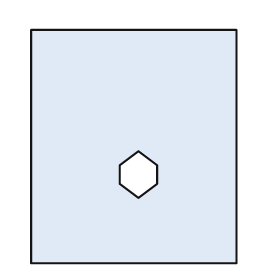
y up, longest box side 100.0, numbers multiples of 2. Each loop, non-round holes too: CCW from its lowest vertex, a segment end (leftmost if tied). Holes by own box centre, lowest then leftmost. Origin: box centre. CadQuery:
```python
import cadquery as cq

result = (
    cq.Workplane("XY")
    .moveTo(-44.0, -50.0)
    .lineTo(44.0, -50.0)
    .lineTo(44.0, 50.0)
    .lineTo(-44.0, 50.0)
    .close()
    .moveTo(2.0, -22.0)
    .lineTo(10.0, -16.0)
    .lineTo(10.0, -8.0)
    .lineTo(2.0, -2.0)
    .lineTo(-6.0, -8.0)
    .lineTo(-6.0, -16.0)
    .close()
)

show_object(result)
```